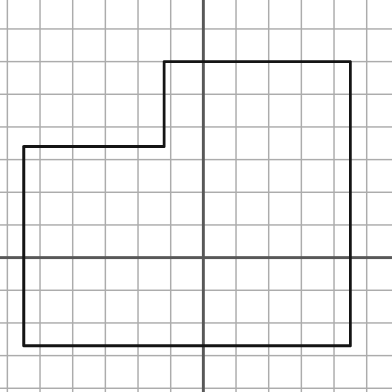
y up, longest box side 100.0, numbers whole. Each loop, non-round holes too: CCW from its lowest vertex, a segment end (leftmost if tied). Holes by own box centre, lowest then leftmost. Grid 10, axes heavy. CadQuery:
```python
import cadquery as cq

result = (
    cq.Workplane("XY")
    .moveTo(-55.0, -27.0)
    .lineTo(45.0, -27.0)
    .lineTo(45.0, 60.0)
    .lineTo(-12.0, 60.0)
    .lineTo(-12.0, 34.0)
    .lineTo(-55.0, 34.0)
    .close()
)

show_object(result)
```